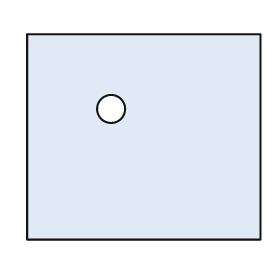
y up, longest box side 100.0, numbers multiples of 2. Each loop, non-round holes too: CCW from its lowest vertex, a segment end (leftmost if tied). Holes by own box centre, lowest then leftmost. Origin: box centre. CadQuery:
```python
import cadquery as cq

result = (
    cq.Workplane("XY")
    .moveTo(-50.0, -44.0)
    .lineTo(50.0, -44.0)
    .lineTo(50.0, 44.0)
    .lineTo(-50.0, 44.0)
    .close()
    .moveTo(-14.0, 12.0)
    .circle(6.0)
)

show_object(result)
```